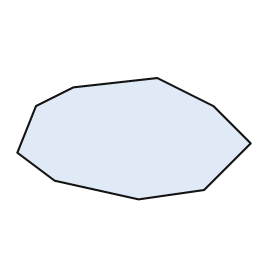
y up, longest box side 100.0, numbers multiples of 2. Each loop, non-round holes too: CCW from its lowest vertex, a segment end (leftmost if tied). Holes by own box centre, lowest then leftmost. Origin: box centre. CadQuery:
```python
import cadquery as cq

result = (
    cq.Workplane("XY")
    .moveTo(2.0, -26.0)
    .lineTo(30.0, -22.0)
    .lineTo(50.0, -2.0)
    .lineTo(34.0, 14.0)
    .lineTo(10.0, 26.0)
    .lineTo(-26.0, 22.0)
    .lineTo(-42.0, 14.0)
    .lineTo(-50.0, -6.0)
    .lineTo(-34.0, -18.0)
    .close()
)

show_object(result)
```